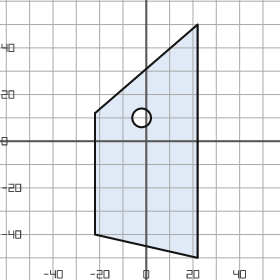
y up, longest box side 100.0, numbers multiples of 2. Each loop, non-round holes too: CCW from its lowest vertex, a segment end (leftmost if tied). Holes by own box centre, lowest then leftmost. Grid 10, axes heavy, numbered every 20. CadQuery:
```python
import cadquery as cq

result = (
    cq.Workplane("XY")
    .moveTo(22.0, -50.0)
    .lineTo(22.0, 50.0)
    .lineTo(-22.0, 12.0)
    .lineTo(-22.0, -40.0)
    .close()
    .moveTo(-2.0, 10.0)
    .circle(4.0)
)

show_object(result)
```